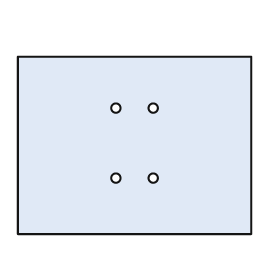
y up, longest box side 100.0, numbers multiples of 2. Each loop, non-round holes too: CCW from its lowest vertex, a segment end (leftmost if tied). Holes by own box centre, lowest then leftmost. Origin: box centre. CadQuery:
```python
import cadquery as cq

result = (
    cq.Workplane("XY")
    .moveTo(-50.0, -38.0)
    .lineTo(50.0, -38.0)
    .lineTo(50.0, 38.0)
    .lineTo(-50.0, 38.0)
    .close()
    .moveTo(-8.0, -14.0)
    .circle(2.0)
    .moveTo(8.0, -14.0)
    .circle(2.0)
    .moveTo(-8.0, 16.0)
    .circle(2.0)
    .moveTo(8.0, 16.0)
    .circle(2.0)
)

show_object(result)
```